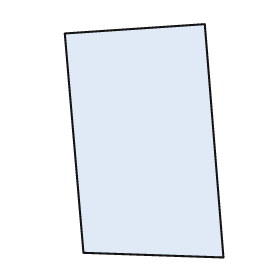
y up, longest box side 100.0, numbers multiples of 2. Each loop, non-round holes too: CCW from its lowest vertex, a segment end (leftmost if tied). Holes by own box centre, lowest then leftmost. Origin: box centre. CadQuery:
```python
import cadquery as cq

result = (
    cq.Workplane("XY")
    .moveTo(34.0, -50.0)
    .lineTo(26.0, 50.0)
    .lineTo(-34.0, 46.0)
    .lineTo(-26.0, -48.0)
    .close()
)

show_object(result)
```